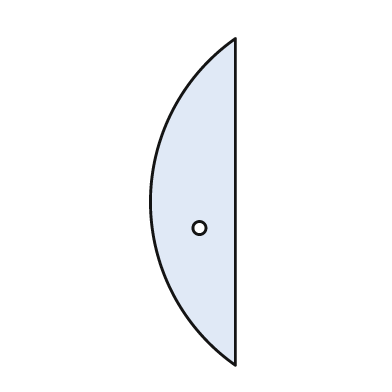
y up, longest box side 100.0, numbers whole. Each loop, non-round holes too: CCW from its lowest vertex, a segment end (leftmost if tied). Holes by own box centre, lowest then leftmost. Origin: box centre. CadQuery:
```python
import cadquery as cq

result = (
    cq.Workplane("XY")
    .moveTo(13.0, -50.0)
    .lineTo(13.0, 50.0)
    .threePointArc((-13.0, 0.0), (13.0, -50.0))
    .close()
    .moveTo(2.0, -8.0)
    .circle(2.0)
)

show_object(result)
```